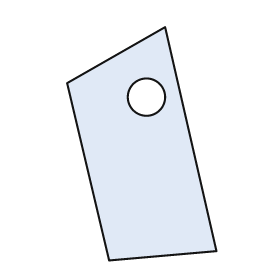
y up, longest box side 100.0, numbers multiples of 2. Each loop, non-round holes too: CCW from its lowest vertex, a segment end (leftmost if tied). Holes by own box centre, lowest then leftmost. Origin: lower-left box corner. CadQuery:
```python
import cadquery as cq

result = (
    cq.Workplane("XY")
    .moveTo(18.0, 0.0)
    .lineTo(64.0, 4.0)
    .lineTo(42.0, 100.0)
    .lineTo(0.0, 76.0)
    .close()
    .moveTo(34.0, 70.0)
    .circle(8.0)
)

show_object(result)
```